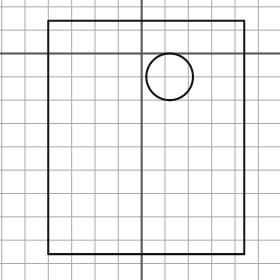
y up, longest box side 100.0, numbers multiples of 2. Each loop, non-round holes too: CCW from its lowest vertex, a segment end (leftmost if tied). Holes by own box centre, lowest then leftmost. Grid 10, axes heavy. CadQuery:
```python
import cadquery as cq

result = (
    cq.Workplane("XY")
    .moveTo(-40.0, -86.0)
    .lineTo(44.0, -86.0)
    .lineTo(44.0, 14.0)
    .lineTo(-40.0, 14.0)
    .close()
    .moveTo(12.0, -10.0)
    .circle(10.0)
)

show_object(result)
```